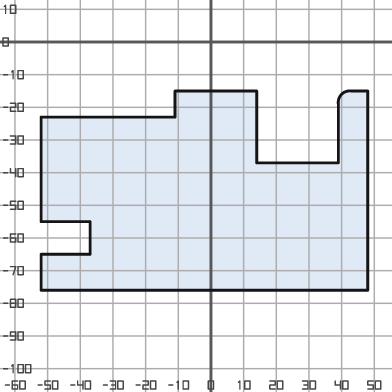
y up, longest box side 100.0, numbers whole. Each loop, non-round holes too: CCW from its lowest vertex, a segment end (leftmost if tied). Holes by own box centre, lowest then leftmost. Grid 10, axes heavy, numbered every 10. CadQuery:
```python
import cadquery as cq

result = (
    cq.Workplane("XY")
    .moveTo(-52.0, -76.0)
    .lineTo(48.0, -76.0)
    .lineTo(48.0, -15.0)
    .lineTo(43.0, -15.0)
    .threePointArc((40.0, -16.0), (39.0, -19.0))
    .lineTo(39.0, -37.0)
    .lineTo(14.0, -37.0)
    .lineTo(14.0, -15.0)
    .lineTo(-11.0, -15.0)
    .lineTo(-11.0, -23.0)
    .lineTo(-52.0, -23.0)
    .lineTo(-52.0, -55.0)
    .lineTo(-37.0, -55.0)
    .lineTo(-37.0, -65.0)
    .lineTo(-52.0, -65.0)
    .close()
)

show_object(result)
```